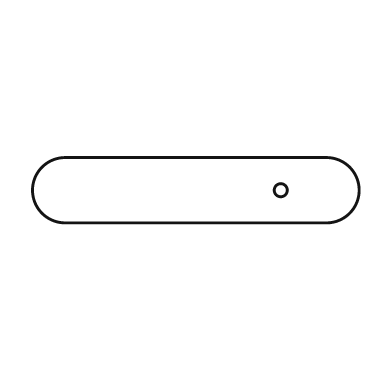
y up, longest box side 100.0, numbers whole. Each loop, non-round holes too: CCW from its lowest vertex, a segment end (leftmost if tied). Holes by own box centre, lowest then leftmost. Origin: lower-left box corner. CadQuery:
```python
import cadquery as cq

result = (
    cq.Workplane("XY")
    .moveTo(10.0, 0.0)
    .lineTo(90.0, 0.0)
    .threePointArc((100.0, 10.0), (90.0, 20.0))
    .lineTo(10.0, 20.0)
    .threePointArc((0.0, 10.0), (10.0, 0.0))
    .close()
    .moveTo(76.0, 10.0)
    .circle(2.0)
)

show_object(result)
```